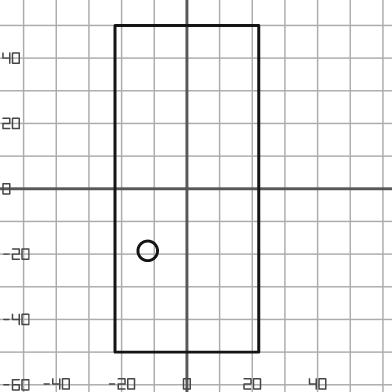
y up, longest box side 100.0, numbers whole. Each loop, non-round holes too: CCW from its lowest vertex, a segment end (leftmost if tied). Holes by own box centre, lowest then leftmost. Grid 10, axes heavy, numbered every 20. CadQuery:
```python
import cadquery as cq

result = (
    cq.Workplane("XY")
    .moveTo(-22.0, -50.0)
    .lineTo(22.0, -50.0)
    .lineTo(22.0, 50.0)
    .lineTo(-22.0, 50.0)
    .close()
    .moveTo(-12.0, -19.0)
    .circle(3.0)
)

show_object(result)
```